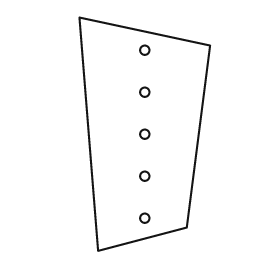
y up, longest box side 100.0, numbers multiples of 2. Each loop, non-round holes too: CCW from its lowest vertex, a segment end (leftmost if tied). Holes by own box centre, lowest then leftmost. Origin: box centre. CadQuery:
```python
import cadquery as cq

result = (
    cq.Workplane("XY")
    .moveTo(-20.0, -50.0)
    .lineTo(18.0, -40.0)
    .lineTo(28.0, 38.0)
    .lineTo(-28.0, 50.0)
    .close()
    .moveTo(0.0, -36.0)
    .circle(2.0)
    .moveTo(0.0, -18.0)
    .circle(2.0)
    .moveTo(0.0, 0.0)
    .circle(2.0)
    .moveTo(0.0, 18.0)
    .circle(2.0)
    .moveTo(0.0, 36.0)
    .circle(2.0)
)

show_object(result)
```